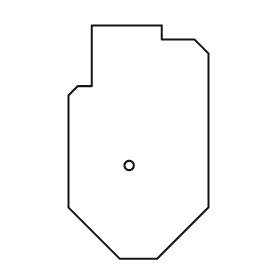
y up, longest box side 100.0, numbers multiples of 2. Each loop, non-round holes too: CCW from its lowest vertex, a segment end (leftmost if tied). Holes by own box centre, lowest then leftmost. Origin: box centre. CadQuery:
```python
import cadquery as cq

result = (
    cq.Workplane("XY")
    .moveTo(-8.0, -50.0)
    .lineTo(8.0, -50.0)
    .lineTo(30.0, -28.0)
    .lineTo(30.0, 38.0)
    .lineTo(24.0, 44.0)
    .lineTo(10.0, 44.0)
    .lineTo(10.0, 50.0)
    .lineTo(-20.0, 50.0)
    .lineTo(-20.0, 24.0)
    .lineTo(-26.0, 24.0)
    .lineTo(-30.0, 20.0)
    .lineTo(-30.0, -28.0)
    .close()
    .moveTo(-4.0, -10.0)
    .circle(2.0)
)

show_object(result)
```